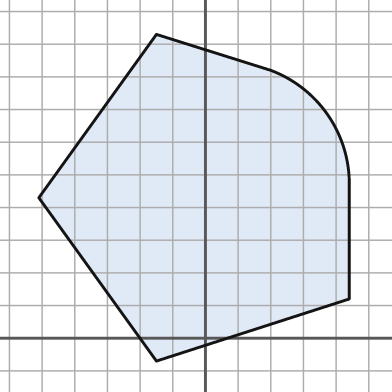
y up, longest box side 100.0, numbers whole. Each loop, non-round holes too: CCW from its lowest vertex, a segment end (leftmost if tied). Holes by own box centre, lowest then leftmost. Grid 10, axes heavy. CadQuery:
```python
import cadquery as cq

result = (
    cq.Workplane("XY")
    .moveTo(-15.0, -7.0)
    .lineTo(44.0, 12.0)
    .lineTo(44.0, 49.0)
    .threePointArc((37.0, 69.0), (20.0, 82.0))
    .lineTo(-15.0, 93.0)
    .lineTo(-51.0, 43.0)
    .close()
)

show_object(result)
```